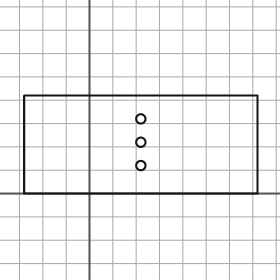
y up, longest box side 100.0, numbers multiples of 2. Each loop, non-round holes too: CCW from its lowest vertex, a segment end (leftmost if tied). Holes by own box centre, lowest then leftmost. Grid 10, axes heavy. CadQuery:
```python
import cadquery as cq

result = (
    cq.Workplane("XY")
    .moveTo(-28.0, 0.0)
    .lineTo(72.0, 0.0)
    .lineTo(72.0, 42.0)
    .lineTo(-28.0, 42.0)
    .close()
    .moveTo(22.0, 12.0)
    .circle(2.0)
    .moveTo(22.0, 22.0)
    .circle(2.0)
    .moveTo(22.0, 32.0)
    .circle(2.0)
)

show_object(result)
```